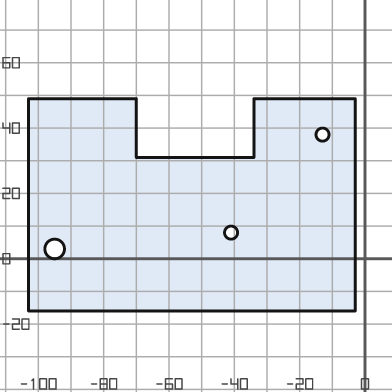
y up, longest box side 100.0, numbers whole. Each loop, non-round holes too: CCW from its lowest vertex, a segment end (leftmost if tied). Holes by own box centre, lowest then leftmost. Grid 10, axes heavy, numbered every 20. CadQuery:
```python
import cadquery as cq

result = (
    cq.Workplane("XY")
    .moveTo(-103.0, -16.0)
    .lineTo(-3.0, -16.0)
    .lineTo(-3.0, 49.0)
    .lineTo(-34.0, 49.0)
    .lineTo(-34.0, 31.0)
    .lineTo(-70.0, 31.0)
    .lineTo(-70.0, 49.0)
    .lineTo(-103.0, 49.0)
    .close()
    .moveTo(-95.0, 3.0)
    .circle(3.0)
    .moveTo(-41.0, 8.0)
    .circle(2.0)
    .moveTo(-13.0, 38.0)
    .circle(2.0)
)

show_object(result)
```